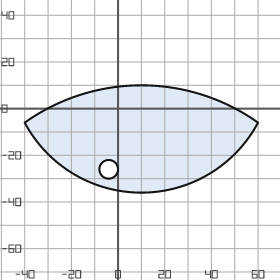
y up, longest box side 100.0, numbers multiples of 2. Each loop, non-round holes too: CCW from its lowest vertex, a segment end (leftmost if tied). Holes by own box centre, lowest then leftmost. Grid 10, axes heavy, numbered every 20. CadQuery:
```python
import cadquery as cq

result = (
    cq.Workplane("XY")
    .moveTo(-40.0, -6.0)
    .threePointArc((10.0, -36.0), (60.0, -6.0))
    .threePointArc((10.0, 10.0), (-40.0, -6.0))
    .close()
    .moveTo(-4.0, -26.0)
    .circle(4.0)
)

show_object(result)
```